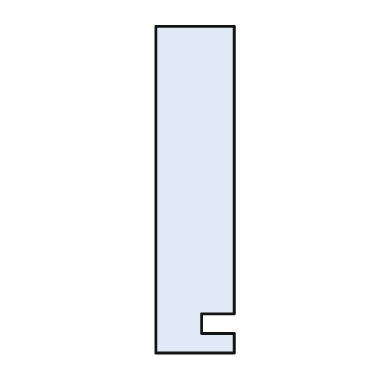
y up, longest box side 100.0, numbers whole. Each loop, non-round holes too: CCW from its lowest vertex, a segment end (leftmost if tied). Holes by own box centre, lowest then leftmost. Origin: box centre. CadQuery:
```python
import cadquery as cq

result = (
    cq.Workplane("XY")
    .moveTo(-12.0, -50.0)
    .lineTo(12.0, -50.0)
    .lineTo(12.0, -44.0)
    .lineTo(2.0, -44.0)
    .lineTo(2.0, -38.0)
    .lineTo(12.0, -38.0)
    .lineTo(12.0, 50.0)
    .lineTo(-12.0, 50.0)
    .close()
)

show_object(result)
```